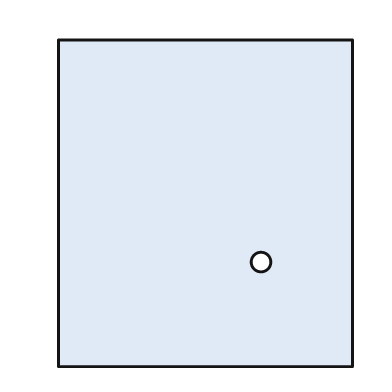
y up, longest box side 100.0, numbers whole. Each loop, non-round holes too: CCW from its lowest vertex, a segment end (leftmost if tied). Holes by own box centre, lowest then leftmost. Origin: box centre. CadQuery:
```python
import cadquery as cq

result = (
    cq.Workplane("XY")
    .moveTo(-45.0, -50.0)
    .lineTo(45.0, -50.0)
    .lineTo(45.0, 50.0)
    .lineTo(-45.0, 50.0)
    .close()
    .moveTo(17.0, -18.0)
    .circle(3.0)
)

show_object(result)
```